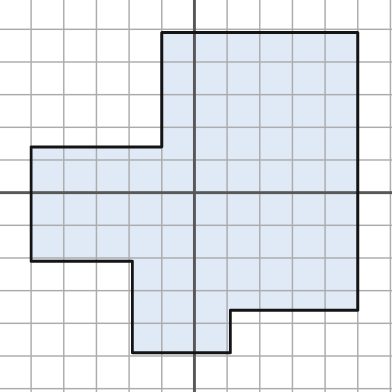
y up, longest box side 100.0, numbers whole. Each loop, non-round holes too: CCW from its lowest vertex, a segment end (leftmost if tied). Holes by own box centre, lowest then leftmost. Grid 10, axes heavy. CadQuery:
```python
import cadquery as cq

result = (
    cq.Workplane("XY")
    .moveTo(-19.0, -49.0)
    .lineTo(11.0, -49.0)
    .lineTo(11.0, -36.0)
    .lineTo(50.0, -36.0)
    .lineTo(50.0, 49.0)
    .lineTo(-10.0, 49.0)
    .lineTo(-10.0, 14.0)
    .lineTo(-50.0, 14.0)
    .lineTo(-50.0, -21.0)
    .lineTo(-19.0, -21.0)
    .close()
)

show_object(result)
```